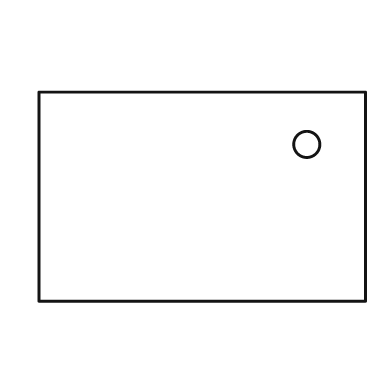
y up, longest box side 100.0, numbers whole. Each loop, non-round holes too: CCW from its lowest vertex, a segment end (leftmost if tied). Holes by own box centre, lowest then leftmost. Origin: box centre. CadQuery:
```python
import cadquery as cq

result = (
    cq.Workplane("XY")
    .moveTo(-50.0, -32.0)
    .lineTo(50.0, -32.0)
    .lineTo(50.0, 32.0)
    .lineTo(-50.0, 32.0)
    .close()
    .moveTo(32.0, 16.0)
    .circle(4.0)
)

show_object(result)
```